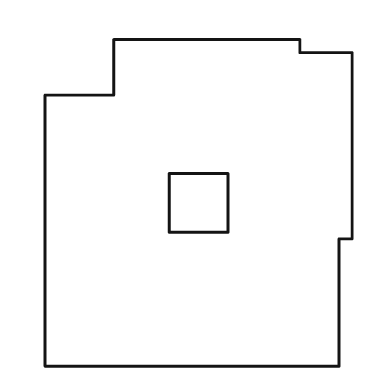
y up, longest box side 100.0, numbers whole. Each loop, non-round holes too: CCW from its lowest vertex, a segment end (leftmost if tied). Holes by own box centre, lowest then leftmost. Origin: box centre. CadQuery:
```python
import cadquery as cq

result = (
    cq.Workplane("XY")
    .moveTo(-47.0, -50.0)
    .lineTo(43.0, -50.0)
    .lineTo(43.0, -11.0)
    .lineTo(47.0, -11.0)
    .lineTo(47.0, 46.0)
    .lineTo(31.0, 46.0)
    .lineTo(31.0, 50.0)
    .lineTo(-26.0, 50.0)
    .lineTo(-26.0, 33.0)
    .lineTo(-47.0, 33.0)
    .close()
    .moveTo(-9.0, -9.0)
    .lineTo(9.0, -9.0)
    .lineTo(9.0, 9.0)
    .lineTo(-9.0, 9.0)
    .close()
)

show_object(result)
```